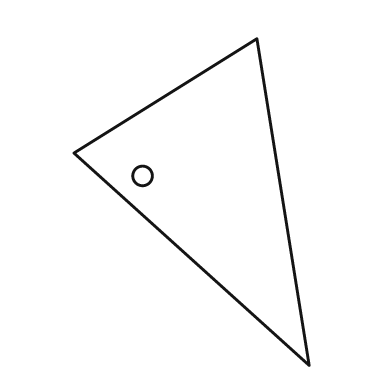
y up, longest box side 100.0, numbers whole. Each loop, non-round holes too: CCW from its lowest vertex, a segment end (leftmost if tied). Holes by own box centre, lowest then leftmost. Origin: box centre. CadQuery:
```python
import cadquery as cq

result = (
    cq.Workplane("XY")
    .moveTo(36.0, -50.0)
    .lineTo(20.0, 50.0)
    .lineTo(-36.0, 15.0)
    .close()
    .moveTo(-15.0, 8.0)
    .circle(3.0)
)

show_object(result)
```